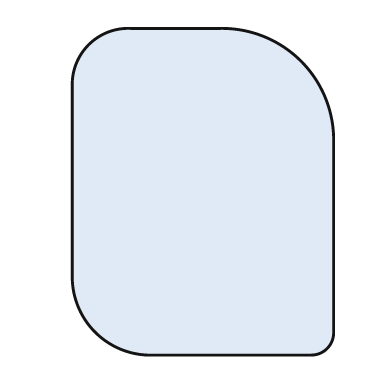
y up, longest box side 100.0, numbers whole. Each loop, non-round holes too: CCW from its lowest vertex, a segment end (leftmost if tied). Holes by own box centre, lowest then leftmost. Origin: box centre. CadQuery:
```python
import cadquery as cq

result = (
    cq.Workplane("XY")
    .moveTo(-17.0, -50.0)
    .lineTo(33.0, -50.0)
    .threePointArc((38.0, -48.0), (40.0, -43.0))
    .lineTo(40.0, 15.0)
    .threePointArc((30.0, 40.0), (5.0, 50.0))
    .lineTo(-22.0, 50.0)
    .threePointArc((-35.0, 45.0), (-40.0, 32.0))
    .lineTo(-40.0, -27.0)
    .threePointArc((-33.0, -43.0), (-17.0, -50.0))
    .close()
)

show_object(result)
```